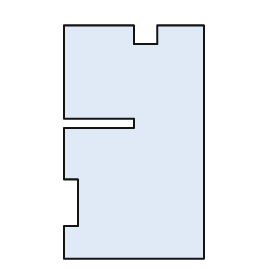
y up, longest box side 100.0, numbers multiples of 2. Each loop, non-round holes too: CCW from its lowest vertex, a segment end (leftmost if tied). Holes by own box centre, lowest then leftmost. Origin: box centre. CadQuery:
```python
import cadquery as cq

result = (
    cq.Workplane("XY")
    .moveTo(-30.0, -50.0)
    .lineTo(30.0, -50.0)
    .lineTo(30.0, 50.0)
    .lineTo(10.0, 50.0)
    .lineTo(10.0, 42.0)
    .lineTo(0.0, 42.0)
    .lineTo(0.0, 50.0)
    .lineTo(-30.0, 50.0)
    .lineTo(-30.0, 10.0)
    .lineTo(0.0, 10.0)
    .lineTo(0.0, 6.0)
    .lineTo(-30.0, 6.0)
    .lineTo(-30.0, -16.0)
    .lineTo(-24.0, -16.0)
    .lineTo(-24.0, -36.0)
    .lineTo(-30.0, -36.0)
    .close()
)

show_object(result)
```